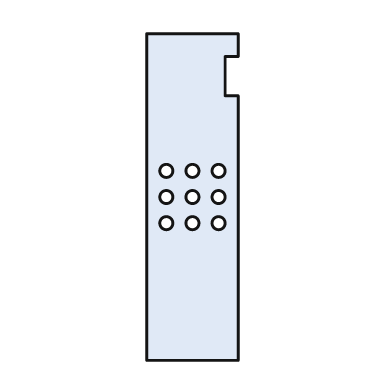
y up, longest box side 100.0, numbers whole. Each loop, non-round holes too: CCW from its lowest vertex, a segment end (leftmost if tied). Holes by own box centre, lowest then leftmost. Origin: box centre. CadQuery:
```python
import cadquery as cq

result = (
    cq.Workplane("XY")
    .moveTo(-14.0, -50.0)
    .lineTo(14.0, -50.0)
    .lineTo(14.0, 31.0)
    .lineTo(10.0, 31.0)
    .lineTo(10.0, 43.0)
    .lineTo(14.0, 43.0)
    .lineTo(14.0, 50.0)
    .lineTo(-14.0, 50.0)
    .close()
    .moveTo(-8.0, -8.0)
    .circle(2.0)
    .moveTo(0.0, -8.0)
    .circle(2.0)
    .moveTo(8.0, -8.0)
    .circle(2.0)
    .moveTo(-8.0, 0.0)
    .circle(2.0)
    .moveTo(0.0, 0.0)
    .circle(2.0)
    .moveTo(8.0, 0.0)
    .circle(2.0)
    .moveTo(-8.0, 8.0)
    .circle(2.0)
    .moveTo(0.0, 8.0)
    .circle(2.0)
    .moveTo(8.0, 8.0)
    .circle(2.0)
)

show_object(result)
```